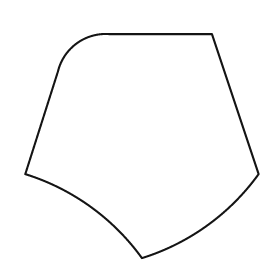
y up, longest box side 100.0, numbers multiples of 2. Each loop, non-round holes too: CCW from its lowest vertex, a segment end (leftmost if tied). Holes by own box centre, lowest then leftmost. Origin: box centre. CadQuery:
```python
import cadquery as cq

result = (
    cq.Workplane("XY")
    .moveTo(0.0, -48.0)
    .threePointArc((28.0, -34.0), (50.0, -12.0))
    .lineTo(30.0, 48.0)
    .lineTo(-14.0, 48.0)
    .threePointArc((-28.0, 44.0), (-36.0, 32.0))
    .lineTo(-50.0, -12.0)
    .threePointArc((-22.0, -26.0), (0.0, -48.0))
    .close()
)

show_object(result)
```